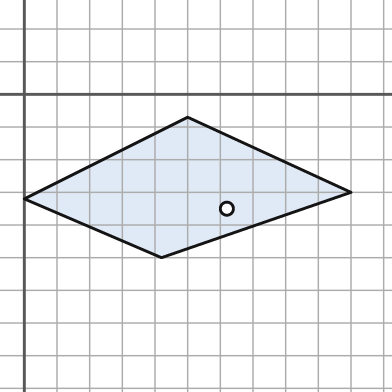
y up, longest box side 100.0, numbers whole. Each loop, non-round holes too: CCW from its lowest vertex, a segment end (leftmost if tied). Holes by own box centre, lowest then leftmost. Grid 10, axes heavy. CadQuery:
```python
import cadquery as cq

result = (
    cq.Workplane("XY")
    .moveTo(42.0, -50.0)
    .lineTo(100.0, -30.0)
    .lineTo(50.0, -7.0)
    .lineTo(0.0, -32.0)
    .close()
    .moveTo(62.0, -35.0)
    .circle(2.0)
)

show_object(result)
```